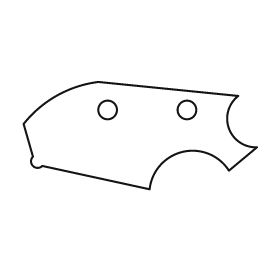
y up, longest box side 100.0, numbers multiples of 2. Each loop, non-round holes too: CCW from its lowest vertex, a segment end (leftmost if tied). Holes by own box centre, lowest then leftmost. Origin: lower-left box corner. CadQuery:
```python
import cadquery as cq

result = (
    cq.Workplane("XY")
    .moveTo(54.0, 0.0)
    .threePointArc((68.0, 16.0), (88.0, 8.0))
    .lineTo(100.0, 18.0)
    .threePointArc((88.0, 26.0), (92.0, 40.0))
    .lineTo(32.0, 46.0)
    .threePointArc((14.0, 40.0), (0.0, 28.0))
    .lineTo(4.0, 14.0)
    .threePointArc((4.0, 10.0), (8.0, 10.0))
    .close()
    .moveTo(36.0, 34.0)
    .circle(4.0)
    .moveTo(70.0, 34.0)
    .circle(4.0)
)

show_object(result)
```